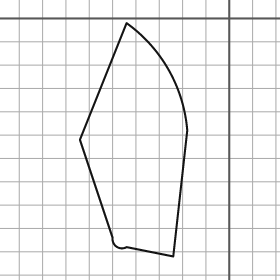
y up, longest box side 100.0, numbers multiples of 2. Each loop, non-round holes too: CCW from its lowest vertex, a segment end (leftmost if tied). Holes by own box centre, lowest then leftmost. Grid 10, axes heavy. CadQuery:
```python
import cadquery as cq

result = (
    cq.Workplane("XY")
    .moveTo(-24.0, -102.0)
    .lineTo(-18.0, -48.0)
    .threePointArc((-26.0, -22.0), (-44.0, -2.0))
    .lineTo(-64.0, -52.0)
    .lineTo(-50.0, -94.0)
    .threePointArc((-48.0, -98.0), (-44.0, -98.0))
    .close()
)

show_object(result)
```